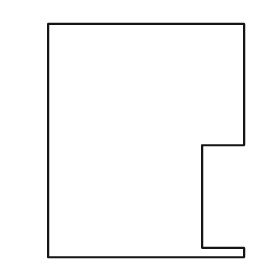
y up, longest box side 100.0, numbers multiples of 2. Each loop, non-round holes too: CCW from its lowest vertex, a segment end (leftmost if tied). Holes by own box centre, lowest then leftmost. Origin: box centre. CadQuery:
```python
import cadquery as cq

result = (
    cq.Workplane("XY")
    .moveTo(-42.0, -50.0)
    .lineTo(42.0, -50.0)
    .lineTo(42.0, -46.0)
    .lineTo(24.0, -46.0)
    .lineTo(24.0, -2.0)
    .lineTo(42.0, -2.0)
    .lineTo(42.0, 50.0)
    .lineTo(-42.0, 50.0)
    .close()
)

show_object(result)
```